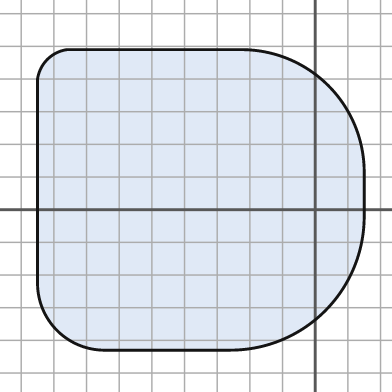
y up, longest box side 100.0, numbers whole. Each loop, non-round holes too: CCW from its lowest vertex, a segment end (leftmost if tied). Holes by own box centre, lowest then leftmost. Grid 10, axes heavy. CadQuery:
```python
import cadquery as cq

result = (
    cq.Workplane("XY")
    .moveTo(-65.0, -43.0)
    .lineTo(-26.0, -43.0)
    .threePointArc((3.0, -31.0), (15.0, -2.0))
    .lineTo(15.0, 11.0)
    .threePointArc((4.0, 38.0), (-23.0, 49.0))
    .lineTo(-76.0, 49.0)
    .threePointArc((-82.0, 46.0), (-85.0, 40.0))
    .lineTo(-85.0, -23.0)
    .threePointArc((-79.0, -37.0), (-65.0, -43.0))
    .close()
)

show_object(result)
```